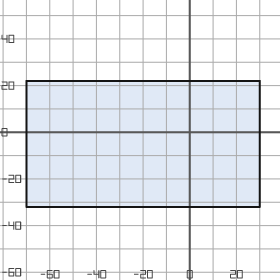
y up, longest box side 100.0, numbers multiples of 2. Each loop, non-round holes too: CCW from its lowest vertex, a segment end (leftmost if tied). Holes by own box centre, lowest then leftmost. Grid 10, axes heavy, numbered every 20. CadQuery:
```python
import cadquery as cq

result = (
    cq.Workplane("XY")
    .moveTo(-70.0, -32.0)
    .lineTo(30.0, -32.0)
    .lineTo(30.0, 22.0)
    .lineTo(-70.0, 22.0)
    .close()
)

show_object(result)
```